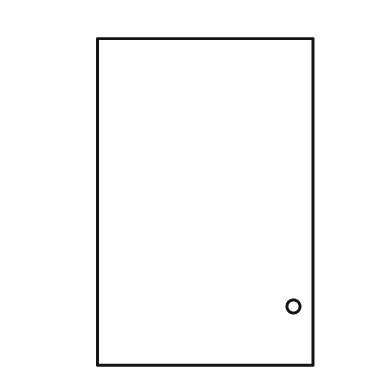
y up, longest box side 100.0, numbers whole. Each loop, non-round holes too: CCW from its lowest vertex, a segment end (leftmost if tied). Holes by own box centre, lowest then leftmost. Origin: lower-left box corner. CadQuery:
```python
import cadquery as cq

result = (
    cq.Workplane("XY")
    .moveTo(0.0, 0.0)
    .lineTo(66.0, 0.0)
    .lineTo(66.0, 100.0)
    .lineTo(0.0, 100.0)
    .close()
    .moveTo(60.0, 18.0)
    .circle(2.0)
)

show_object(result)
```